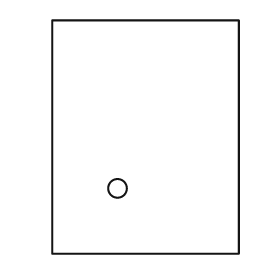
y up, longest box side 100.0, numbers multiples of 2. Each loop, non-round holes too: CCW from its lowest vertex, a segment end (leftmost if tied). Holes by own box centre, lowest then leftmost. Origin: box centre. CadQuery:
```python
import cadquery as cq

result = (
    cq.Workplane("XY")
    .moveTo(-40.0, -50.0)
    .lineTo(40.0, -50.0)
    .lineTo(40.0, 50.0)
    .lineTo(-40.0, 50.0)
    .close()
    .moveTo(-12.0, -22.0)
    .circle(4.0)
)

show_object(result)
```